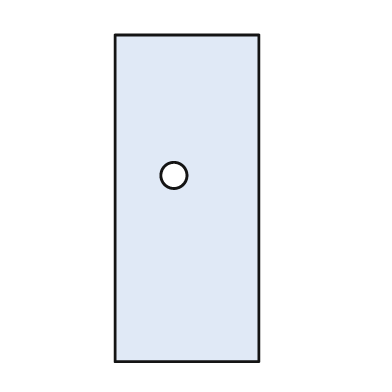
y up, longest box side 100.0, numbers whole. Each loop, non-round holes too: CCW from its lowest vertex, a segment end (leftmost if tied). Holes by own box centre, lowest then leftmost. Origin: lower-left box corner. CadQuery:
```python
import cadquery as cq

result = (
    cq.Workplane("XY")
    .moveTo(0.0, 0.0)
    .lineTo(44.0, 0.0)
    .lineTo(44.0, 100.0)
    .lineTo(0.0, 100.0)
    .close()
    .moveTo(18.0, 57.0)
    .circle(4.0)
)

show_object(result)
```